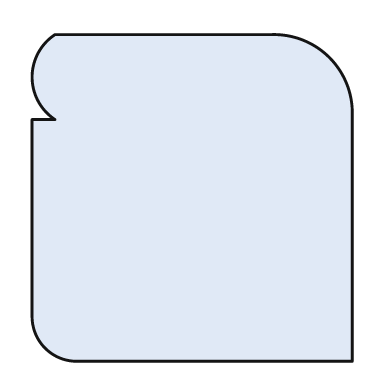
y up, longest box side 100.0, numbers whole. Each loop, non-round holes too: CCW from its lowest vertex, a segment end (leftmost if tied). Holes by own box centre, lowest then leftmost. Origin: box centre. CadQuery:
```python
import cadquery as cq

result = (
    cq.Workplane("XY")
    .moveTo(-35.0, -50.0)
    .lineTo(49.0, -50.0)
    .lineTo(49.0, 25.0)
    .threePointArc((42.0, 43.0), (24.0, 50.0))
    .lineTo(-42.0, 50.0)
    .threePointArc((-49.0, 37.0), (-42.0, 24.0))
    .lineTo(-49.0, 24.0)
    .lineTo(-49.0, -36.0)
    .threePointArc((-45.0, -46.0), (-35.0, -50.0))
    .close()
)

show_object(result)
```